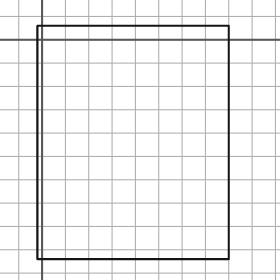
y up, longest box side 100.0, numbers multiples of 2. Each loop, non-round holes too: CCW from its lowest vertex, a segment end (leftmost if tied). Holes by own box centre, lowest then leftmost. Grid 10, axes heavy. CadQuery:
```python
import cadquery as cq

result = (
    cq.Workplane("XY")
    .moveTo(-2.0, -94.0)
    .lineTo(80.0, -94.0)
    .lineTo(80.0, 6.0)
    .lineTo(-2.0, 6.0)
    .close()
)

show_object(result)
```